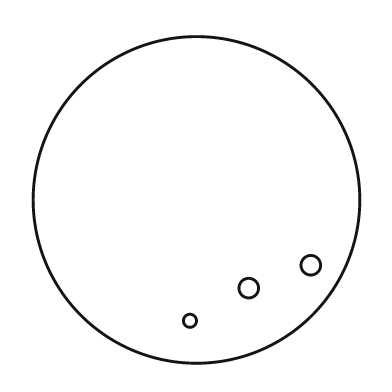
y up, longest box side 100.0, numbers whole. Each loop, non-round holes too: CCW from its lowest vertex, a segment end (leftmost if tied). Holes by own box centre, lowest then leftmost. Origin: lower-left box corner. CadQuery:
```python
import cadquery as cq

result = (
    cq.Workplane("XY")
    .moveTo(50.0, 50.0)
    .circle(50.0)
    .moveTo(48.0, 13.0)
    .circle(2.0)
    .moveTo(66.0, 23.0)
    .circle(3.0)
    .moveTo(85.0, 30.0)
    .circle(3.0)
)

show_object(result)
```